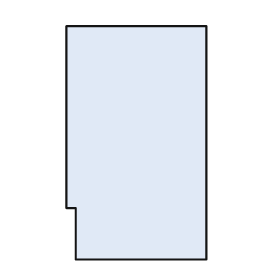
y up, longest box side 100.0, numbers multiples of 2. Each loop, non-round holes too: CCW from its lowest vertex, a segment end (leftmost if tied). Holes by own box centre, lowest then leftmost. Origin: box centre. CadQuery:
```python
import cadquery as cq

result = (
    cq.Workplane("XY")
    .moveTo(-26.0, -50.0)
    .lineTo(30.0, -50.0)
    .lineTo(30.0, 50.0)
    .lineTo(-30.0, 50.0)
    .lineTo(-30.0, -28.0)
    .lineTo(-26.0, -28.0)
    .close()
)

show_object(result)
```